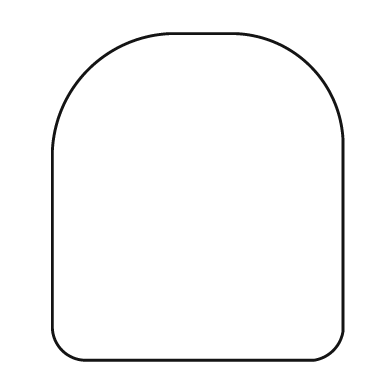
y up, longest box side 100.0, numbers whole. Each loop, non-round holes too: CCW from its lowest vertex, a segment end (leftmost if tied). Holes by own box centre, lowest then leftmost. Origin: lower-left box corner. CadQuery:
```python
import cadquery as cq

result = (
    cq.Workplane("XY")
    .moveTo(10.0, 0.0)
    .lineTo(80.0, 0.0)
    .threePointArc((86.0, 3.0), (89.0, 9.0))
    .lineTo(89.0, 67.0)
    .threePointArc((79.0, 90.0), (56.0, 100.0))
    .lineTo(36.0, 100.0)
    .threePointArc((11.0, 89.0), (0.0, 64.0))
    .lineTo(0.0, 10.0)
    .threePointArc((3.0, 3.0), (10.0, 0.0))
    .close()
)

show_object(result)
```